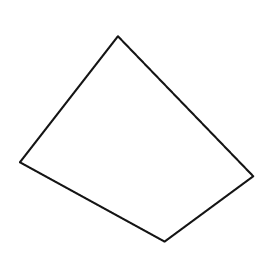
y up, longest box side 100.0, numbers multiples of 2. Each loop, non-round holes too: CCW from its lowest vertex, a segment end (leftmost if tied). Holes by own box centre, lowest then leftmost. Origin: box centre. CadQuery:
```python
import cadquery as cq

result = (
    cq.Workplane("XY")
    .moveTo(12.0, -44.0)
    .lineTo(50.0, -16.0)
    .lineTo(-8.0, 44.0)
    .lineTo(-50.0, -10.0)
    .close()
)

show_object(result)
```